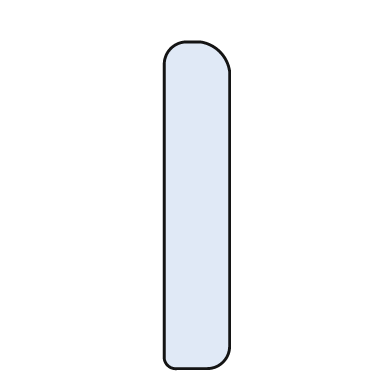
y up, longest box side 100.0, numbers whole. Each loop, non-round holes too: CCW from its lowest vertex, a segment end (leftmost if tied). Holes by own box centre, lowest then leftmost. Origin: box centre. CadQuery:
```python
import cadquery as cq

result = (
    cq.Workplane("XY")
    .moveTo(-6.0, -50.0)
    .lineTo(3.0, -50.0)
    .threePointArc((8.0, -48.0), (10.0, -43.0))
    .lineTo(10.0, 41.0)
    .threePointArc((7.0, 47.0), (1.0, 50.0))
    .lineTo(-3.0, 50.0)
    .threePointArc((-8.0, 48.0), (-10.0, 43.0))
    .lineTo(-10.0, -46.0)
    .threePointArc((-9.0, -49.0), (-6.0, -50.0))
    .close()
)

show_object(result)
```